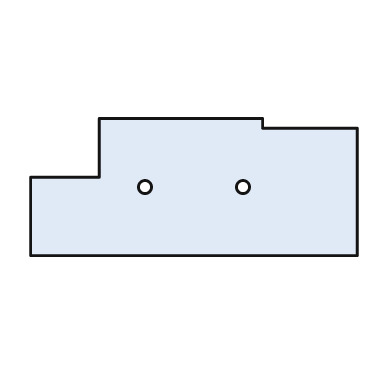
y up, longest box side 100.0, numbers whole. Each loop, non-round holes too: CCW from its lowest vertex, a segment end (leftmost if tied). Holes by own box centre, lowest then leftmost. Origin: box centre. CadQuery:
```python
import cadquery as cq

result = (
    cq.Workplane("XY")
    .moveTo(-50.0, -21.0)
    .lineTo(50.0, -21.0)
    .lineTo(50.0, 18.0)
    .lineTo(21.0, 18.0)
    .lineTo(21.0, 21.0)
    .lineTo(-29.0, 21.0)
    .lineTo(-29.0, 3.0)
    .lineTo(-50.0, 3.0)
    .close()
    .moveTo(-15.0, 0.0)
    .circle(2.0)
    .moveTo(15.0, 0.0)
    .circle(2.0)
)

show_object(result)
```